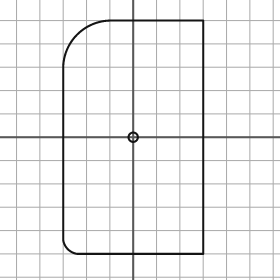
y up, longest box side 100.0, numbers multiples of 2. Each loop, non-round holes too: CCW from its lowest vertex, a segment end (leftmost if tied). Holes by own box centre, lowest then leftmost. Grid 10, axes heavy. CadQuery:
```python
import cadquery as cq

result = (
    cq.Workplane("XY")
    .moveTo(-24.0, -50.0)
    .lineTo(30.0, -50.0)
    .lineTo(30.0, 50.0)
    .lineTo(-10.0, 50.0)
    .threePointArc((-24.0, 44.0), (-30.0, 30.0))
    .lineTo(-30.0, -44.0)
    .threePointArc((-28.0, -48.0), (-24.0, -50.0))
    .close()
    .moveTo(0.0, 0.0)
    .circle(2.0)
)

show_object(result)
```